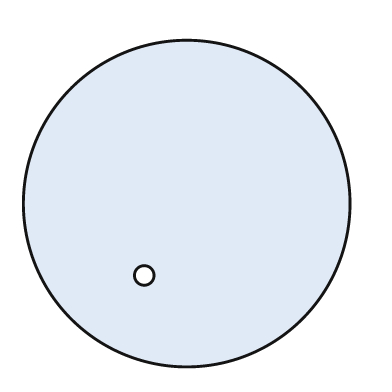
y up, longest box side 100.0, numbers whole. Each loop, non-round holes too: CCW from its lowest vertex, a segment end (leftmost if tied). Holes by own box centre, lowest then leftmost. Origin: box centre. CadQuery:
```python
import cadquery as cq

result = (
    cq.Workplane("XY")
    .moveTo(0.0, 0.0)
    .circle(50.0)
    .moveTo(-13.0, -22.0)
    .circle(3.0)
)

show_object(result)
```